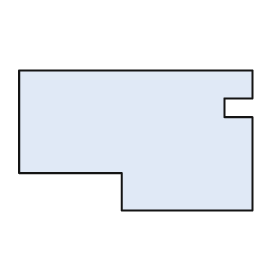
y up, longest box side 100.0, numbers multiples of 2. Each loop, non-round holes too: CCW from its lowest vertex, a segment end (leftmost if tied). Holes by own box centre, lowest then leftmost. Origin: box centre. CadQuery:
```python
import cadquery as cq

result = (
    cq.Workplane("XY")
    .moveTo(-6.0, -30.0)
    .lineTo(50.0, -30.0)
    .lineTo(50.0, 10.0)
    .lineTo(38.0, 10.0)
    .lineTo(38.0, 18.0)
    .lineTo(50.0, 18.0)
    .lineTo(50.0, 30.0)
    .lineTo(-50.0, 30.0)
    .lineTo(-50.0, -14.0)
    .lineTo(-6.0, -14.0)
    .close()
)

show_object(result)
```